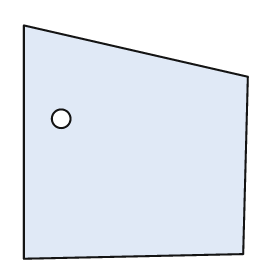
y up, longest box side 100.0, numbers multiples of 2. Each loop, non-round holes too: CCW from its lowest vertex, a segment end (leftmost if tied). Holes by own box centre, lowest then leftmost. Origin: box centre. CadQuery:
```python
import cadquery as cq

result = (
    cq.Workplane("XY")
    .moveTo(-48.0, -50.0)
    .lineTo(46.0, -48.0)
    .lineTo(48.0, 28.0)
    .lineTo(-48.0, 50.0)
    .close()
    .moveTo(-32.0, 10.0)
    .circle(4.0)
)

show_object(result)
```